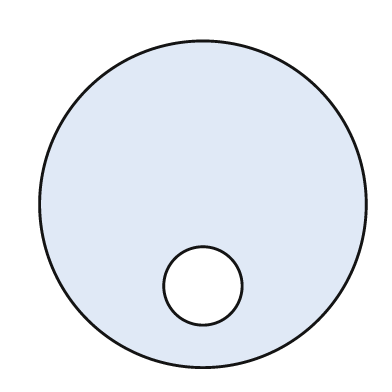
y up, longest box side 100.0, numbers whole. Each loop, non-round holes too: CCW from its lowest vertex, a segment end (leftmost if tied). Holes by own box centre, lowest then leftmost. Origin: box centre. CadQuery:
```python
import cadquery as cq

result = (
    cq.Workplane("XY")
    .moveTo(0.0, 0.0)
    .circle(50.0)
    .moveTo(0.0, -25.0)
    .circle(12.0)
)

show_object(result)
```